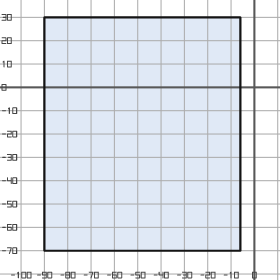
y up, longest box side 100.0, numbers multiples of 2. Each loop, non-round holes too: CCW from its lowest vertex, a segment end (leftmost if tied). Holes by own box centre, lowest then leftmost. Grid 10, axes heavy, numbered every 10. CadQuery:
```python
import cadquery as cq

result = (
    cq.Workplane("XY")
    .moveTo(-90.0, -70.0)
    .lineTo(-6.0, -70.0)
    .lineTo(-6.0, 30.0)
    .lineTo(-90.0, 30.0)
    .close()
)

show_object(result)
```